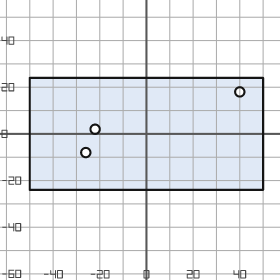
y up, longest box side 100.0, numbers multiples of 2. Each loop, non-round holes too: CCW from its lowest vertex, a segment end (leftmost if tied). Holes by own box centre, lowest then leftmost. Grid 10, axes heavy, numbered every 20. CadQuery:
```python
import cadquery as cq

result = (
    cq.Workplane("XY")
    .moveTo(-50.0, -24.0)
    .lineTo(50.0, -24.0)
    .lineTo(50.0, 24.0)
    .lineTo(-50.0, 24.0)
    .close()
    .moveTo(-26.0, -8.0)
    .circle(2.0)
    .moveTo(-22.0, 2.0)
    .circle(2.0)
    .moveTo(40.0, 18.0)
    .circle(2.0)
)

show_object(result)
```